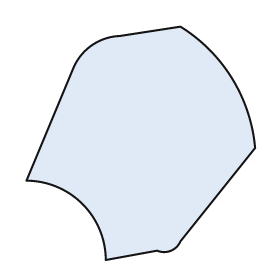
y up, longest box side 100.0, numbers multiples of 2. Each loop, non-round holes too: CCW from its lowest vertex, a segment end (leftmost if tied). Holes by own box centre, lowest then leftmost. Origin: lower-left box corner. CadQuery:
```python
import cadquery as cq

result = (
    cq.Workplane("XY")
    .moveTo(34.0, 0.0)
    .lineTo(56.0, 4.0)
    .threePointArc((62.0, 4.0), (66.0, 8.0))
    .lineTo(98.0, 48.0)
    .threePointArc((88.0, 78.0), (66.0, 100.0))
    .lineTo(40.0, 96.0)
    .threePointArc((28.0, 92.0), (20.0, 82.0))
    .lineTo(0.0, 34.0)
    .threePointArc((24.0, 24.0), (34.0, 0.0))
    .close()
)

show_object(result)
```